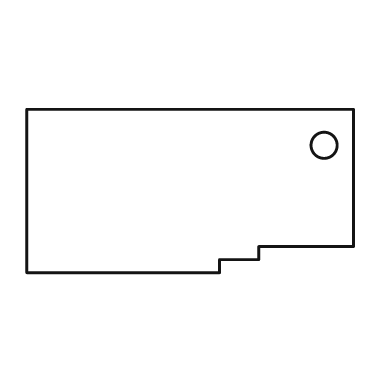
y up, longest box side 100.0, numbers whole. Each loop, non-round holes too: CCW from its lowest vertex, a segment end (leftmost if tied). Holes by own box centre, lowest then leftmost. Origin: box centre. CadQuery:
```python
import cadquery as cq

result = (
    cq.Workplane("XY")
    .moveTo(-50.0, -25.0)
    .lineTo(9.0, -25.0)
    .lineTo(9.0, -21.0)
    .lineTo(21.0, -21.0)
    .lineTo(21.0, -17.0)
    .lineTo(50.0, -17.0)
    .lineTo(50.0, 25.0)
    .lineTo(-50.0, 25.0)
    .close()
    .moveTo(41.0, 14.0)
    .circle(4.0)
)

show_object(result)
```